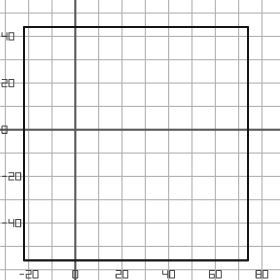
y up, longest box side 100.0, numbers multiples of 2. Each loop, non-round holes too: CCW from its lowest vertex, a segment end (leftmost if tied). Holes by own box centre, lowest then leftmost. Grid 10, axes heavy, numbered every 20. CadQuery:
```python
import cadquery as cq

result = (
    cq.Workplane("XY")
    .moveTo(-22.0, -56.0)
    .lineTo(74.0, -56.0)
    .lineTo(74.0, 44.0)
    .lineTo(-22.0, 44.0)
    .close()
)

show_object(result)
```